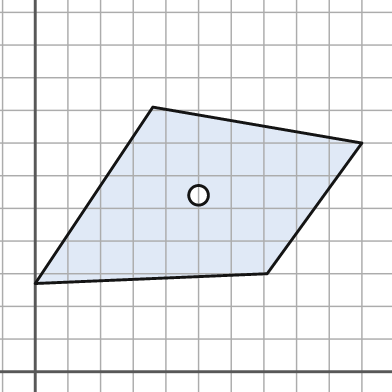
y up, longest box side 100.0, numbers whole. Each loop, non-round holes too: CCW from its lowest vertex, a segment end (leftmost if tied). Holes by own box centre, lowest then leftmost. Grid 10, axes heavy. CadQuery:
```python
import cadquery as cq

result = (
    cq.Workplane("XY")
    .moveTo(0.0, 27.0)
    .lineTo(71.0, 30.0)
    .lineTo(100.0, 70.0)
    .lineTo(36.0, 81.0)
    .close()
    .moveTo(50.0, 54.0)
    .circle(3.0)
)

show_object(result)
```